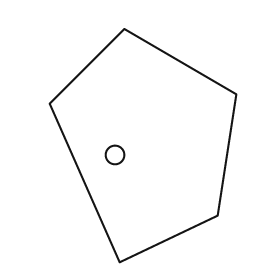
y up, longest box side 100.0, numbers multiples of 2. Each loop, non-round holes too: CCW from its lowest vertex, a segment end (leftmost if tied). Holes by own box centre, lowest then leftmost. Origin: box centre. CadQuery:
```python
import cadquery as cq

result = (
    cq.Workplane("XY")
    .moveTo(-10.0, -50.0)
    .lineTo(32.0, -30.0)
    .lineTo(40.0, 22.0)
    .lineTo(-8.0, 50.0)
    .lineTo(-40.0, 18.0)
    .close()
    .moveTo(-12.0, -4.0)
    .circle(4.0)
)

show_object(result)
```